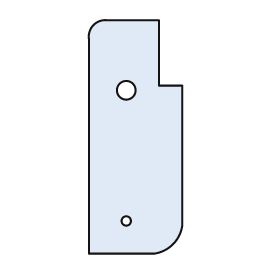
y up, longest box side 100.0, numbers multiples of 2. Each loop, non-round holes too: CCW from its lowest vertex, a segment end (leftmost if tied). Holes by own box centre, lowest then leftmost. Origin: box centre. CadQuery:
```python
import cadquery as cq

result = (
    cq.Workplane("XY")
    .moveTo(-20.0, -50.0)
    .lineTo(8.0, -50.0)
    .threePointArc((16.0, -46.0), (20.0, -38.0))
    .lineTo(20.0, 22.0)
    .lineTo(10.0, 22.0)
    .lineTo(10.0, 50.0)
    .lineTo(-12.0, 50.0)
    .threePointArc((-18.0, 48.0), (-20.0, 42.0))
    .close()
    .moveTo(-4.0, -36.0)
    .circle(2.0)
    .moveTo(-4.0, 20.0)
    .circle(4.0)
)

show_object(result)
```